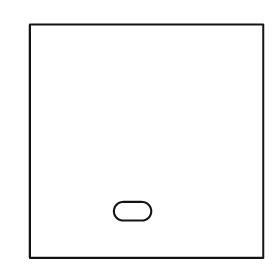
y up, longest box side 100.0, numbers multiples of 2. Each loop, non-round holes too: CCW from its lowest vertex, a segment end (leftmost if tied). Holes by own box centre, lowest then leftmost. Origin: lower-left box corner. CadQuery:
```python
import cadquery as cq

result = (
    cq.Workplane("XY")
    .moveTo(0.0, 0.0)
    .lineTo(100.0, 0.0)
    .lineTo(100.0, 100.0)
    .lineTo(0.0, 100.0)
    .close()
    .moveTo(40.0, 16.0)
    .lineTo(48.0, 16.0)
    .threePointArc((52.0, 20.0), (48.0, 24.0))
    .lineTo(40.0, 24.0)
    .threePointArc((36.0, 20.0), (40.0, 16.0))
    .close()
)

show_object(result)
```